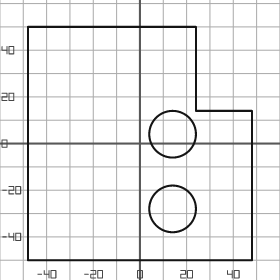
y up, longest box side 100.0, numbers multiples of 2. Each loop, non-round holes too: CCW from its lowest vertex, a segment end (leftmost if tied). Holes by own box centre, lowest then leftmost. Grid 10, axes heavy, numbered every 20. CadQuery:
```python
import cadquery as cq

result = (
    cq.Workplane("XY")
    .moveTo(-48.0, -50.0)
    .lineTo(48.0, -50.0)
    .lineTo(48.0, 14.0)
    .lineTo(24.0, 14.0)
    .lineTo(24.0, 50.0)
    .lineTo(-48.0, 50.0)
    .close()
    .moveTo(14.0, -28.0)
    .circle(10.0)
    .moveTo(14.0, 4.0)
    .circle(10.0)
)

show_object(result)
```